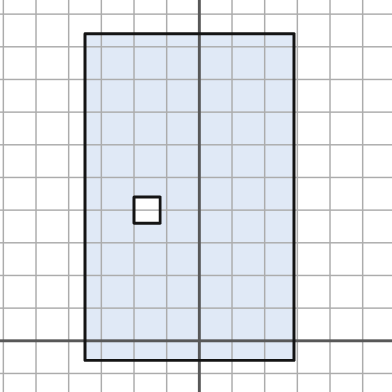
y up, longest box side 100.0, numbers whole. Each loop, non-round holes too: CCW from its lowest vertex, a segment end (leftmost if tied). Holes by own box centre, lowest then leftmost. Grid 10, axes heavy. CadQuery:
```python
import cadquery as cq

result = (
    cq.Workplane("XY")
    .moveTo(-35.0, -6.0)
    .lineTo(29.0, -6.0)
    .lineTo(29.0, 94.0)
    .lineTo(-35.0, 94.0)
    .close()
    .moveTo(-20.0, 36.0)
    .lineTo(-12.0, 36.0)
    .lineTo(-12.0, 44.0)
    .lineTo(-20.0, 44.0)
    .close()
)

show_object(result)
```